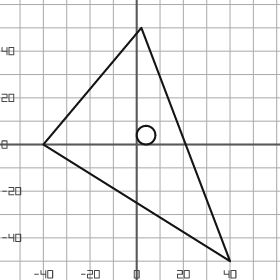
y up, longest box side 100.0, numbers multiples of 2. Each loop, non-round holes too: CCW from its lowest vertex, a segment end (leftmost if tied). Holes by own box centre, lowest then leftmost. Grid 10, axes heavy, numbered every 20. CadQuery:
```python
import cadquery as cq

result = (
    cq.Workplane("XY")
    .moveTo(40.0, -50.0)
    .lineTo(2.0, 50.0)
    .lineTo(-40.0, 0.0)
    .close()
    .moveTo(4.0, 4.0)
    .circle(4.0)
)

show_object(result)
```